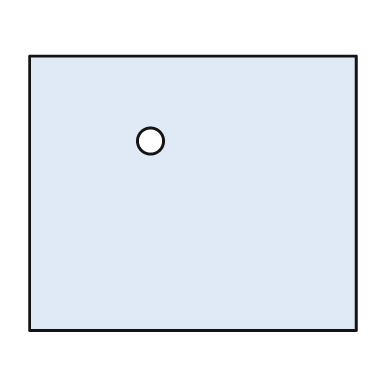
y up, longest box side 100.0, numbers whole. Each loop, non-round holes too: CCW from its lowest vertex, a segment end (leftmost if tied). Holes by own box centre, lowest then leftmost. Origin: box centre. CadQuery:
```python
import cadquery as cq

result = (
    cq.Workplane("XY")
    .moveTo(-50.0, -42.0)
    .lineTo(50.0, -42.0)
    .lineTo(50.0, 42.0)
    .lineTo(-50.0, 42.0)
    .close()
    .moveTo(-13.0, 16.0)
    .circle(4.0)
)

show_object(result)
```